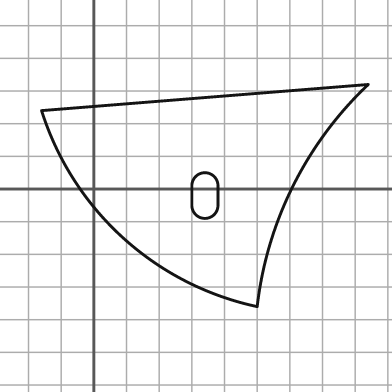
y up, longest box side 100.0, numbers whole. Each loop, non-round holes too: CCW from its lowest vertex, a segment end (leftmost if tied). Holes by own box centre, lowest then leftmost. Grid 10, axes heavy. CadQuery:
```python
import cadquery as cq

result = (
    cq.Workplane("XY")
    .moveTo(50.0, -36.0)
    .threePointArc((61.0, 1.0), (84.0, 32.0))
    .lineTo(-16.0, 24.0)
    .threePointArc((9.0, -15.0), (50.0, -36.0))
    .close()
    .moveTo(30.0, -5.0)
    .threePointArc((34.0, -9.0), (38.0, -5.0))
    .lineTo(38.0, 1.0)
    .threePointArc((34.0, 5.0), (30.0, 1.0))
    .close()
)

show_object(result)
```